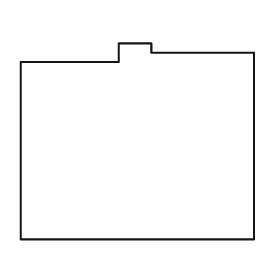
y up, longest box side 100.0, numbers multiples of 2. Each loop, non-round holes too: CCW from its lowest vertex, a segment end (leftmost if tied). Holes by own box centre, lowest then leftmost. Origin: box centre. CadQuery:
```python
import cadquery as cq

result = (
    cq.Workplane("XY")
    .moveTo(-50.0, -42.0)
    .lineTo(50.0, -42.0)
    .lineTo(50.0, 38.0)
    .lineTo(6.0, 38.0)
    .lineTo(6.0, 42.0)
    .lineTo(-8.0, 42.0)
    .lineTo(-8.0, 34.0)
    .lineTo(-50.0, 34.0)
    .close()
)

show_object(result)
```